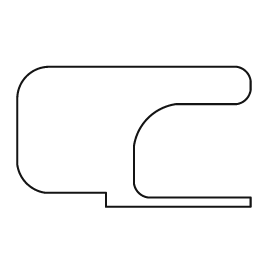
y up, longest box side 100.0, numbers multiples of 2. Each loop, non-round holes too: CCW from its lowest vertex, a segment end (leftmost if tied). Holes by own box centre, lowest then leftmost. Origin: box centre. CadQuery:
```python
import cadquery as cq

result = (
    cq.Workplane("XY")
    .moveTo(-12.0, -30.0)
    .lineTo(50.0, -30.0)
    .lineTo(50.0, -26.0)
    .lineTo(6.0, -26.0)
    .threePointArc((2.0, -24.0), (0.0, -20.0))
    .lineTo(0.0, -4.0)
    .threePointArc((6.0, 8.0), (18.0, 14.0))
    .lineTo(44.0, 14.0)
    .threePointArc((48.0, 16.0), (50.0, 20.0))
    .lineTo(50.0, 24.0)
    .threePointArc((48.0, 28.0), (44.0, 30.0))
    .lineTo(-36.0, 30.0)
    .threePointArc((-46.0, 26.0), (-50.0, 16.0))
    .lineTo(-50.0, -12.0)
    .threePointArc((-46.0, -20.0), (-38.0, -24.0))
    .lineTo(-12.0, -24.0)
    .close()
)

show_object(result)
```